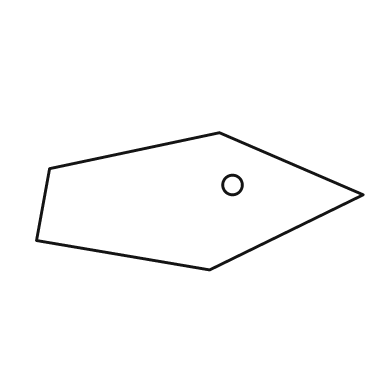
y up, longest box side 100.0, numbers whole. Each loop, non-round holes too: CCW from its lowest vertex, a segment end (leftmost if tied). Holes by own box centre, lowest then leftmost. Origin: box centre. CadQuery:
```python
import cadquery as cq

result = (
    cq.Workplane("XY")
    .moveTo(3.0, -21.0)
    .lineTo(50.0, 2.0)
    .lineTo(6.0, 21.0)
    .lineTo(-46.0, 10.0)
    .lineTo(-50.0, -12.0)
    .close()
    .moveTo(10.0, 5.0)
    .circle(3.0)
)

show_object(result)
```